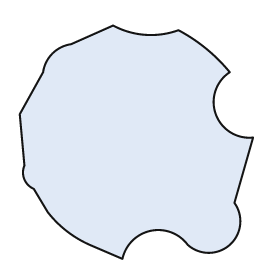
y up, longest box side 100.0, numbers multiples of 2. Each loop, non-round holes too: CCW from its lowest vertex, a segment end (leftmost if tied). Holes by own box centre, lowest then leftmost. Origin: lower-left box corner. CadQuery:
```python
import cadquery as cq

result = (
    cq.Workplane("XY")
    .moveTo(44.0, 0.0)
    .threePointArc((56.0, 12.0), (72.0, 6.0))
    .threePointArc((90.0, 6.0), (92.0, 24.0))
    .lineTo(100.0, 52.0)
    .threePointArc((84.0, 62.0), (90.0, 80.0))
    .threePointArc((80.0, 90.0), (68.0, 98.0))
    .threePointArc((54.0, 96.0), (40.0, 100.0))
    .lineTo(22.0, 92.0)
    .threePointArc((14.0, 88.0), (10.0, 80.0))
    .lineTo(0.0, 62.0)
    .lineTo(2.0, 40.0)
    .threePointArc((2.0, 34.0), (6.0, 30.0))
    .lineTo(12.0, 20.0)
    .threePointArc((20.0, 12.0), (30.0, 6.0))
    .close()
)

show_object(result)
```